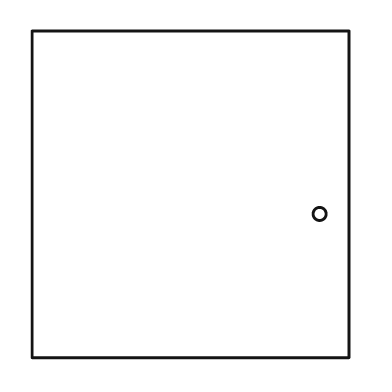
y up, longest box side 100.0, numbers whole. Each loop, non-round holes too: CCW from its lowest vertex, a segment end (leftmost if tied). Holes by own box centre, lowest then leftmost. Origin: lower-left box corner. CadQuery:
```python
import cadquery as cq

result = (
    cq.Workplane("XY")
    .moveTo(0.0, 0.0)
    .lineTo(97.0, 0.0)
    .lineTo(97.0, 100.0)
    .lineTo(0.0, 100.0)
    .close()
    .moveTo(88.0, 44.0)
    .circle(2.0)
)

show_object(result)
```